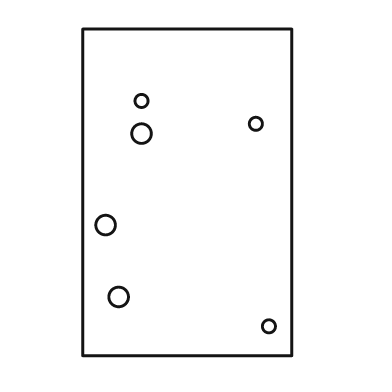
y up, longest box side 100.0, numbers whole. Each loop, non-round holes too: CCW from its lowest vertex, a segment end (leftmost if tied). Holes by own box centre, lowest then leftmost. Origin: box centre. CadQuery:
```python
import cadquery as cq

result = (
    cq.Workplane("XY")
    .moveTo(-32.0, -50.0)
    .lineTo(32.0, -50.0)
    .lineTo(32.0, 50.0)
    .lineTo(-32.0, 50.0)
    .close()
    .moveTo(25.0, -41.0)
    .circle(2.0)
    .moveTo(-21.0, -32.0)
    .circle(3.0)
    .moveTo(-25.0, -10.0)
    .circle(3.0)
    .moveTo(-14.0, 18.0)
    .circle(3.0)
    .moveTo(21.0, 21.0)
    .circle(2.0)
    .moveTo(-14.0, 28.0)
    .circle(2.0)
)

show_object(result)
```